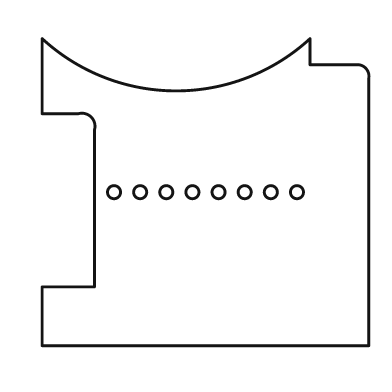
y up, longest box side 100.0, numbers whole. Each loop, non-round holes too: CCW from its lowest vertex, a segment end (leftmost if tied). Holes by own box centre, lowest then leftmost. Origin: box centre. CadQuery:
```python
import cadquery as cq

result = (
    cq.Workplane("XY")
    .moveTo(-50.0, -47.0)
    .lineTo(50.0, -47.0)
    .lineTo(50.0, 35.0)
    .threePointArc((49.0, 38.0), (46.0, 39.0))
    .lineTo(32.0, 39.0)
    .lineTo(32.0, 47.0)
    .threePointArc((-9.0, 31.0), (-50.0, 47.0))
    .lineTo(-50.0, 24.0)
    .lineTo(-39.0, 24.0)
    .threePointArc((-35.0, 23.0), (-34.0, 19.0))
    .lineTo(-34.0, -29.0)
    .lineTo(-50.0, -29.0)
    .close()
    .moveTo(-28.0, 0.0)
    .circle(2.0)
    .moveTo(-20.0, 0.0)
    .circle(2.0)
    .moveTo(-12.0, 0.0)
    .circle(2.0)
    .moveTo(-4.0, 0.0)
    .circle(2.0)
    .moveTo(4.0, 0.0)
    .circle(2.0)
    .moveTo(12.0, 0.0)
    .circle(2.0)
    .moveTo(20.0, 0.0)
    .circle(2.0)
    .moveTo(28.0, 0.0)
    .circle(2.0)
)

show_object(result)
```